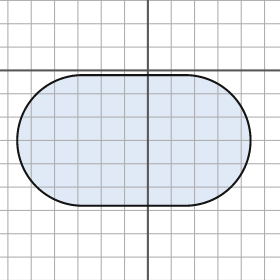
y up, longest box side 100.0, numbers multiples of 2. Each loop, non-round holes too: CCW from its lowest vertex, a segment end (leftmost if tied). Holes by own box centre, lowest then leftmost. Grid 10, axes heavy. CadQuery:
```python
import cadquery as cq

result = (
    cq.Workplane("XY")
    .moveTo(-28.0, -58.0)
    .lineTo(16.0, -58.0)
    .threePointArc((44.0, -30.0), (16.0, -2.0))
    .lineTo(-28.0, -2.0)
    .threePointArc((-56.0, -30.0), (-28.0, -58.0))
    .close()
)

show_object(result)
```